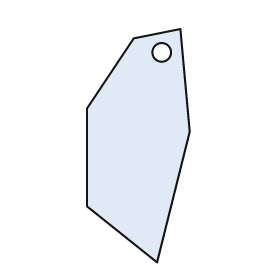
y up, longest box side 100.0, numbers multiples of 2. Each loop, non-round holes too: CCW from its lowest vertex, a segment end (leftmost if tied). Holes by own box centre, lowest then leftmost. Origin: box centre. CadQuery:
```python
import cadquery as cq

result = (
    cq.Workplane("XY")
    .moveTo(8.0, -50.0)
    .lineTo(22.0, 6.0)
    .lineTo(18.0, 50.0)
    .lineTo(-2.0, 46.0)
    .lineTo(-22.0, 16.0)
    .lineTo(-22.0, -26.0)
    .close()
    .moveTo(10.0, 40.0)
    .circle(4.0)
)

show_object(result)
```